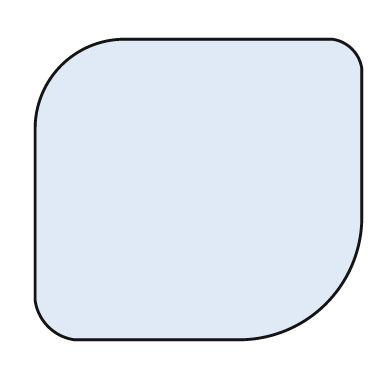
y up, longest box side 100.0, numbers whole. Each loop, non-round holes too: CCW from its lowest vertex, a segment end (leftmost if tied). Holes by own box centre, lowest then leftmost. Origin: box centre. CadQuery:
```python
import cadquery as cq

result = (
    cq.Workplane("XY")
    .moveTo(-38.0, -46.0)
    .lineTo(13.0, -46.0)
    .threePointArc((39.0, -35.0), (50.0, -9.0))
    .lineTo(50.0, 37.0)
    .threePointArc((47.0, 43.0), (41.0, 46.0))
    .lineTo(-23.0, 46.0)
    .threePointArc((-42.0, 38.0), (-50.0, 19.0))
    .lineTo(-50.0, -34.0)
    .threePointArc((-46.0, -42.0), (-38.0, -46.0))
    .close()
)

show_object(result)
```